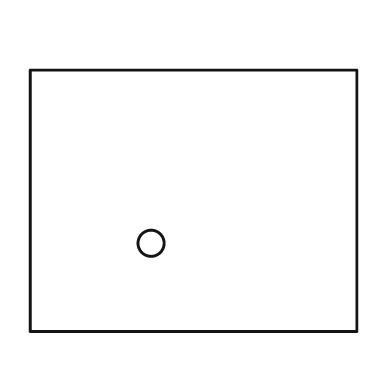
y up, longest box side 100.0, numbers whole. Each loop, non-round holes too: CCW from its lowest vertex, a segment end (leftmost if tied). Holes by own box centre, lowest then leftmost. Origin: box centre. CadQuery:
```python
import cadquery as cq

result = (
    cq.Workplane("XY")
    .moveTo(-50.0, -40.0)
    .lineTo(50.0, -40.0)
    .lineTo(50.0, 40.0)
    .lineTo(-50.0, 40.0)
    .close()
    .moveTo(-13.0, -13.0)
    .circle(4.0)
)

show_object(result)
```